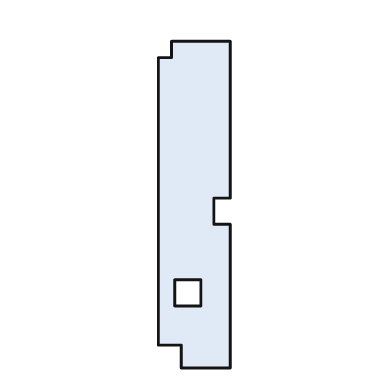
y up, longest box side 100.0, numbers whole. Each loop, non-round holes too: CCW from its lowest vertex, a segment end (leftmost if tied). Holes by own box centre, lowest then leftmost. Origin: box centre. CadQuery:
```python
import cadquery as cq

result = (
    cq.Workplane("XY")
    .moveTo(-4.0, -50.0)
    .lineTo(11.0, -50.0)
    .lineTo(11.0, -6.0)
    .lineTo(6.0, -6.0)
    .lineTo(6.0, 2.0)
    .lineTo(11.0, 2.0)
    .lineTo(11.0, 50.0)
    .lineTo(-7.0, 50.0)
    .lineTo(-7.0, 45.0)
    .lineTo(-11.0, 45.0)
    .lineTo(-11.0, -43.0)
    .lineTo(-4.0, -43.0)
    .close()
    .moveTo(-6.0, -31.0)
    .lineTo(2.0, -31.0)
    .lineTo(2.0, -23.0)
    .lineTo(-6.0, -23.0)
    .close()
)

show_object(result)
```